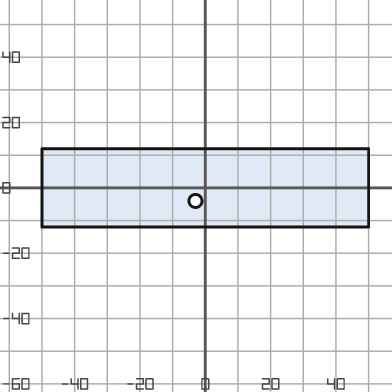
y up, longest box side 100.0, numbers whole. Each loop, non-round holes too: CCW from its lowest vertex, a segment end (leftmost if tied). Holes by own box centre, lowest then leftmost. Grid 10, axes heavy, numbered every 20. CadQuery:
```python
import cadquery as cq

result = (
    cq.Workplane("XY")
    .moveTo(-50.0, -12.0)
    .lineTo(50.0, -12.0)
    .lineTo(50.0, 12.0)
    .lineTo(-50.0, 12.0)
    .close()
    .moveTo(-3.0, -4.0)
    .circle(2.0)
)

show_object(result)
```